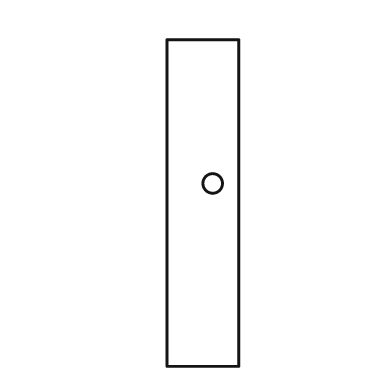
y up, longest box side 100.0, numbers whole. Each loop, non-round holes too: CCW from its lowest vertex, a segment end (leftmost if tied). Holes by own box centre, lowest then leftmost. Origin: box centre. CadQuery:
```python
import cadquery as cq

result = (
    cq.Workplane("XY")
    .moveTo(-11.0, -50.0)
    .lineTo(11.0, -50.0)
    .lineTo(11.0, 50.0)
    .lineTo(-11.0, 50.0)
    .close()
    .moveTo(3.0, 6.0)
    .circle(3.0)
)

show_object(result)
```